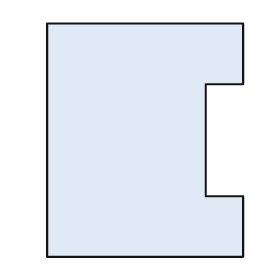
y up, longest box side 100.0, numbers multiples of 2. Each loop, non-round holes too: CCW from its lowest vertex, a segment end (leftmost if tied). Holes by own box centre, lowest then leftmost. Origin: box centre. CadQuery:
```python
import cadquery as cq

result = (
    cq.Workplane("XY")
    .moveTo(-42.0, -50.0)
    .lineTo(42.0, -50.0)
    .lineTo(42.0, -24.0)
    .lineTo(26.0, -24.0)
    .lineTo(26.0, 24.0)
    .lineTo(42.0, 24.0)
    .lineTo(42.0, 50.0)
    .lineTo(-42.0, 50.0)
    .close()
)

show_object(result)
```